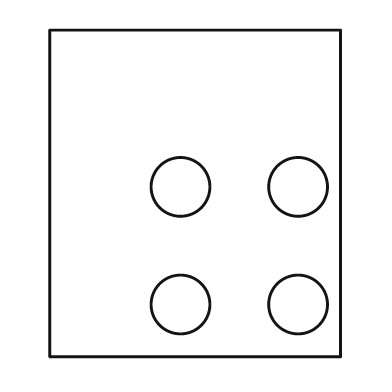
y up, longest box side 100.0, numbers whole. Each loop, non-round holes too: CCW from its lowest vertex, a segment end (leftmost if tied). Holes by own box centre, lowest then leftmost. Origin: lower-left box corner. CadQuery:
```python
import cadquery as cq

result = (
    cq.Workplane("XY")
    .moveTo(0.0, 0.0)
    .lineTo(89.0, 0.0)
    .lineTo(89.0, 100.0)
    .lineTo(0.0, 100.0)
    .close()
    .moveTo(40.0, 16.0)
    .circle(9.0)
    .moveTo(76.0, 16.0)
    .circle(9.0)
    .moveTo(40.0, 52.0)
    .circle(9.0)
    .moveTo(76.0, 52.0)
    .circle(9.0)
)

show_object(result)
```